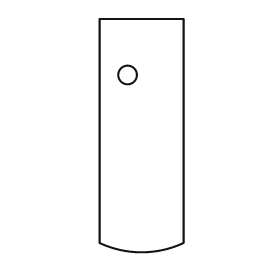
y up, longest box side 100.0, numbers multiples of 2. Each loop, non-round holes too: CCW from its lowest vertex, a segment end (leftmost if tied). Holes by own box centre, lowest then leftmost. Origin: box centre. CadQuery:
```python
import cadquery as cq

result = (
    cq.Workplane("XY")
    .moveTo(-18.0, -46.0)
    .threePointArc((0.0, -50.0), (18.0, -46.0))
    .lineTo(18.0, 50.0)
    .lineTo(-18.0, 50.0)
    .close()
    .moveTo(-6.0, 26.0)
    .circle(4.0)
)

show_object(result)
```